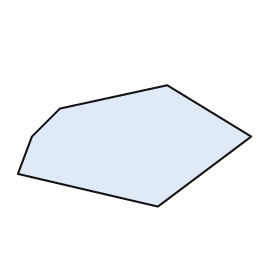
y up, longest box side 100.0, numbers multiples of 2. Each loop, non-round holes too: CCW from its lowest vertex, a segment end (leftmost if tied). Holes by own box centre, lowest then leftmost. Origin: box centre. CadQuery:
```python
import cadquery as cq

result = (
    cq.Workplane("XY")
    .moveTo(10.0, -26.0)
    .lineTo(50.0, 4.0)
    .lineTo(14.0, 26.0)
    .lineTo(-32.0, 16.0)
    .lineTo(-44.0, 4.0)
    .lineTo(-50.0, -12.0)
    .close()
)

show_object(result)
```